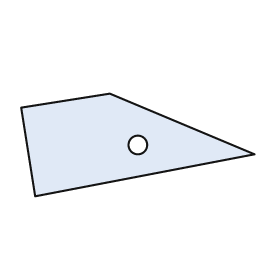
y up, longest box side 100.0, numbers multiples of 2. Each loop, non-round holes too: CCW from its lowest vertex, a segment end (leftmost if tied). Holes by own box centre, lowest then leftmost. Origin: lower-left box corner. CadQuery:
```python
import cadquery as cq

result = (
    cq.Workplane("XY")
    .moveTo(6.0, 0.0)
    .lineTo(100.0, 18.0)
    .lineTo(38.0, 44.0)
    .lineTo(0.0, 38.0)
    .close()
    .moveTo(50.0, 22.0)
    .circle(4.0)
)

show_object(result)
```